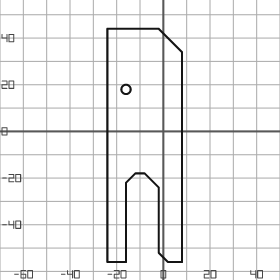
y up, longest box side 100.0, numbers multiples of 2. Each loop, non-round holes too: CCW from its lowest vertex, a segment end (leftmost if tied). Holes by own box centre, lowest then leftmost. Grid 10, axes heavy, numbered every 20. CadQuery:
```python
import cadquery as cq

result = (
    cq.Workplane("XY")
    .moveTo(-24.0, -56.0)
    .lineTo(-16.0, -56.0)
    .lineTo(-16.0, -22.0)
    .lineTo(-12.0, -18.0)
    .lineTo(-8.0, -18.0)
    .lineTo(-2.0, -24.0)
    .lineTo(-2.0, -52.0)
    .lineTo(2.0, -56.0)
    .lineTo(8.0, -56.0)
    .lineTo(8.0, 34.0)
    .lineTo(-2.0, 44.0)
    .lineTo(-24.0, 44.0)
    .close()
    .moveTo(-16.0, 18.0)
    .circle(2.0)
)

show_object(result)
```